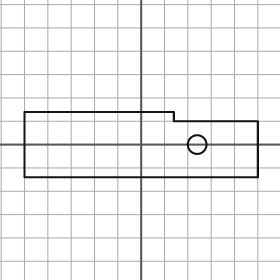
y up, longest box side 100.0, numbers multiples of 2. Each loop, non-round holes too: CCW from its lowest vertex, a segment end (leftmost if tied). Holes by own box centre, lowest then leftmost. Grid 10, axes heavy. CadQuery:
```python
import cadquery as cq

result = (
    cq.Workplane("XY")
    .moveTo(-50.0, -14.0)
    .lineTo(50.0, -14.0)
    .lineTo(50.0, 10.0)
    .lineTo(14.0, 10.0)
    .lineTo(14.0, 14.0)
    .lineTo(-50.0, 14.0)
    .close()
    .moveTo(24.0, 0.0)
    .circle(4.0)
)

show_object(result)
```